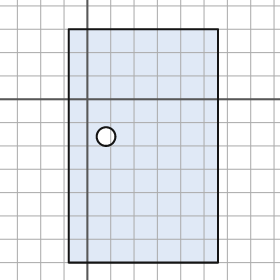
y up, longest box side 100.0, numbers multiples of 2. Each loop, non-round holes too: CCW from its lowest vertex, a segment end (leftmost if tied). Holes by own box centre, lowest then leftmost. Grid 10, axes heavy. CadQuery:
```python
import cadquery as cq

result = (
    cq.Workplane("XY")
    .moveTo(-8.0, -70.0)
    .lineTo(56.0, -70.0)
    .lineTo(56.0, 30.0)
    .lineTo(-8.0, 30.0)
    .close()
    .moveTo(8.0, -16.0)
    .circle(4.0)
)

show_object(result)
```